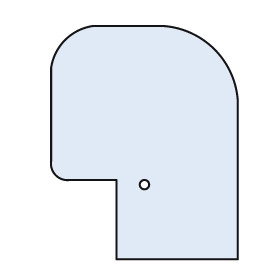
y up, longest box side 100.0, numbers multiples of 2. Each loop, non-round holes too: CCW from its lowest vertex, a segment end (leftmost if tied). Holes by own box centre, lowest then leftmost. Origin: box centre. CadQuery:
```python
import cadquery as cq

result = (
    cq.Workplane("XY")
    .moveTo(-12.0, -50.0)
    .lineTo(40.0, -50.0)
    .lineTo(40.0, 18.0)
    .threePointArc((30.0, 40.0), (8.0, 50.0))
    .lineTo(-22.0, 50.0)
    .threePointArc((-34.0, 44.0), (-40.0, 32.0))
    .lineTo(-40.0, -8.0)
    .threePointArc((-38.0, -14.0), (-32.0, -16.0))
    .lineTo(-12.0, -16.0)
    .close()
    .moveTo(0.0, -18.0)
    .circle(2.0)
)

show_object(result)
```